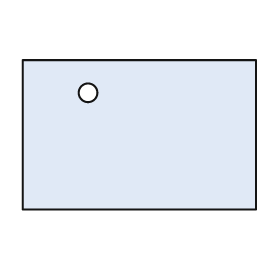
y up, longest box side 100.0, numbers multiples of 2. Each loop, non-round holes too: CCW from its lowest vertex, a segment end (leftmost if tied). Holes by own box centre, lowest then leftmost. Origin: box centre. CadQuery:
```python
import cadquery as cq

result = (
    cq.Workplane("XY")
    .moveTo(-50.0, -32.0)
    .lineTo(50.0, -32.0)
    .lineTo(50.0, 32.0)
    .lineTo(-50.0, 32.0)
    .close()
    .moveTo(-22.0, 18.0)
    .circle(4.0)
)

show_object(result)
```